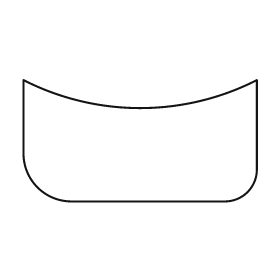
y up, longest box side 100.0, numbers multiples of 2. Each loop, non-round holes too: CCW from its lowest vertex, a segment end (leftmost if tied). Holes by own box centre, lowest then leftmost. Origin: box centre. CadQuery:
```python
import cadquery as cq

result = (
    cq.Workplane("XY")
    .moveTo(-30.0, -26.0)
    .lineTo(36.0, -26.0)
    .threePointArc((46.0, -22.0), (50.0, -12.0))
    .lineTo(50.0, 26.0)
    .threePointArc((0.0, 14.0), (-50.0, 26.0))
    .lineTo(-50.0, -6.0)
    .threePointArc((-44.0, -20.0), (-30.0, -26.0))
    .close()
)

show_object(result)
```